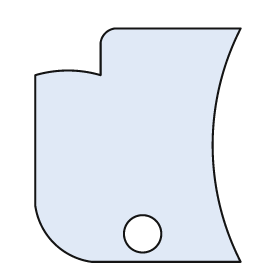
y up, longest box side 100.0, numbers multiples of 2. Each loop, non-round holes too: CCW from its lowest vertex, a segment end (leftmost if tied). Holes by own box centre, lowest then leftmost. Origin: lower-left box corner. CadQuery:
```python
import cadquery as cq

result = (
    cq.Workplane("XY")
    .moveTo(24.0, 0.0)
    .lineTo(88.0, 0.0)
    .threePointArc((76.0, 50.0), (88.0, 100.0))
    .lineTo(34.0, 100.0)
    .threePointArc((30.0, 98.0), (28.0, 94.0))
    .lineTo(28.0, 80.0)
    .threePointArc((14.0, 82.0), (0.0, 80.0))
    .lineTo(0.0, 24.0)
    .threePointArc((8.0, 8.0), (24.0, 0.0))
    .close()
    .moveTo(46.0, 12.0)
    .circle(8.0)
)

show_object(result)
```